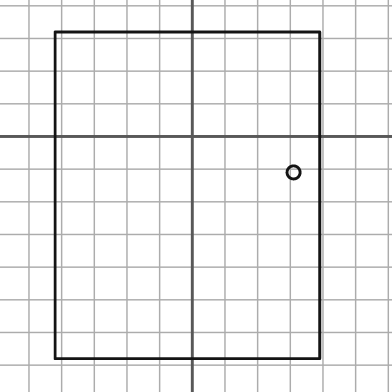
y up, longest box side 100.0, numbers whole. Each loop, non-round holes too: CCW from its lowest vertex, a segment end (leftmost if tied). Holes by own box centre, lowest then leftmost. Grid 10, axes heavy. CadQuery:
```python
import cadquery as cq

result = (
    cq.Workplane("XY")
    .moveTo(-42.0, -68.0)
    .lineTo(39.0, -68.0)
    .lineTo(39.0, 32.0)
    .lineTo(-42.0, 32.0)
    .close()
    .moveTo(31.0, -11.0)
    .circle(2.0)
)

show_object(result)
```